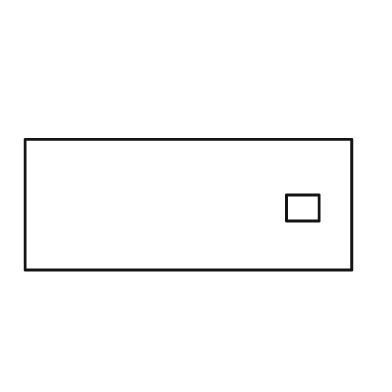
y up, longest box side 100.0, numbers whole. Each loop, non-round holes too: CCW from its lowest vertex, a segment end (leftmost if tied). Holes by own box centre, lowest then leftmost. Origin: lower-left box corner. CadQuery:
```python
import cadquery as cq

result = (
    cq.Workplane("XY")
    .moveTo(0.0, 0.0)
    .lineTo(100.0, 0.0)
    .lineTo(100.0, 40.0)
    .lineTo(0.0, 40.0)
    .close()
    .moveTo(80.0, 15.0)
    .lineTo(90.0, 15.0)
    .lineTo(90.0, 23.0)
    .lineTo(80.0, 23.0)
    .close()
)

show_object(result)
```